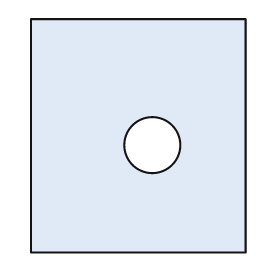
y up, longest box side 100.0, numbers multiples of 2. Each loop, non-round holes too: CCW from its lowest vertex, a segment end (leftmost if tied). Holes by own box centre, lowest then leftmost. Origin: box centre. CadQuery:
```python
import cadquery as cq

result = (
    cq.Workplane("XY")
    .moveTo(-46.0, -50.0)
    .lineTo(46.0, -50.0)
    .lineTo(46.0, 50.0)
    .lineTo(-46.0, 50.0)
    .close()
    .moveTo(6.0, -4.0)
    .circle(12.0)
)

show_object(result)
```